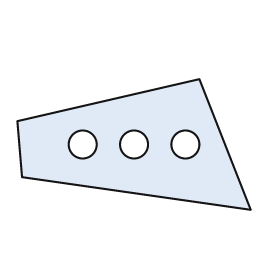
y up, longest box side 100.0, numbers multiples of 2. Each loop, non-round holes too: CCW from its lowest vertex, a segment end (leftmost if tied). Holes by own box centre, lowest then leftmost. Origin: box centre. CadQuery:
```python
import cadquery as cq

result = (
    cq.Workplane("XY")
    .moveTo(50.0, -28.0)
    .lineTo(28.0, 28.0)
    .lineTo(-50.0, 10.0)
    .lineTo(-48.0, -14.0)
    .close()
    .moveTo(-22.0, 0.0)
    .circle(6.0)
    .moveTo(0.0, 0.0)
    .circle(6.0)
    .moveTo(22.0, 0.0)
    .circle(6.0)
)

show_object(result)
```